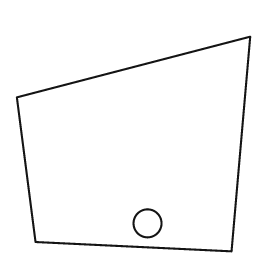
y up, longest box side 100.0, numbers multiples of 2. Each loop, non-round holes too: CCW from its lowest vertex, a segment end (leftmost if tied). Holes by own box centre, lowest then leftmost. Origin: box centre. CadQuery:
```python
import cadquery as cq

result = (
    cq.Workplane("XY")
    .moveTo(42.0, -46.0)
    .lineTo(50.0, 46.0)
    .lineTo(-50.0, 20.0)
    .lineTo(-42.0, -42.0)
    .close()
    .moveTo(6.0, -34.0)
    .circle(6.0)
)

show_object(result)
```